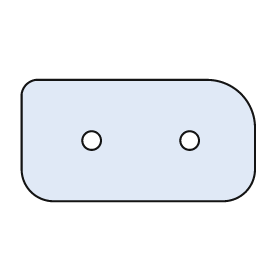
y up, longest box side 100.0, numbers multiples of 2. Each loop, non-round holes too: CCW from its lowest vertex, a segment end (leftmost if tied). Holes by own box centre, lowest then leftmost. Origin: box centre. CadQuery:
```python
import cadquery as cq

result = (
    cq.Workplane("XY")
    .moveTo(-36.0, -26.0)
    .lineTo(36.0, -26.0)
    .threePointArc((46.0, -22.0), (50.0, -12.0))
    .lineTo(50.0, 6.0)
    .threePointArc((44.0, 20.0), (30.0, 26.0))
    .lineTo(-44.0, 26.0)
    .threePointArc((-48.0, 24.0), (-50.0, 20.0))
    .lineTo(-50.0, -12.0)
    .threePointArc((-46.0, -22.0), (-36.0, -26.0))
    .close()
    .moveTo(-20.0, 0.0)
    .circle(4.0)
    .moveTo(22.0, 0.0)
    .circle(4.0)
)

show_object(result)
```